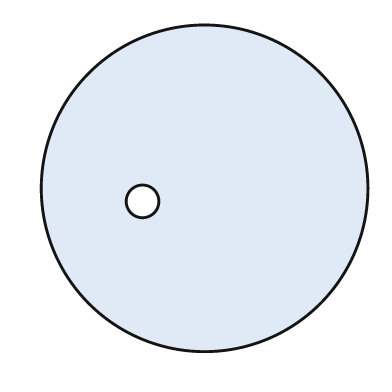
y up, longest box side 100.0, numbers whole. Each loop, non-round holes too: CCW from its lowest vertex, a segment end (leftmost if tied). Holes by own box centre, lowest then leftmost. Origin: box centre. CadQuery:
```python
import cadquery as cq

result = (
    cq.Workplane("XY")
    .moveTo(0.0, 0.0)
    .circle(50.0)
    .moveTo(-19.0, -4.0)
    .circle(5.0)
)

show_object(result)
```